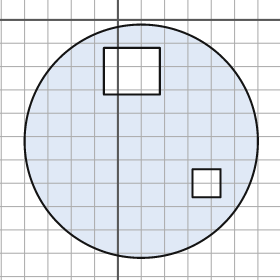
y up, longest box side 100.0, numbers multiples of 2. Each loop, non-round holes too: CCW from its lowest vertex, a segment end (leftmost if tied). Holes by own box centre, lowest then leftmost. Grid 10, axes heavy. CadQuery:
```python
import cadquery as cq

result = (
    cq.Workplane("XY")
    .moveTo(10.0, -52.0)
    .circle(50.0)
    .moveTo(32.0, -76.0)
    .lineTo(44.0, -76.0)
    .lineTo(44.0, -64.0)
    .lineTo(32.0, -64.0)
    .close()
    .moveTo(-6.0, -32.0)
    .lineTo(18.0, -32.0)
    .lineTo(18.0, -12.0)
    .lineTo(-6.0, -12.0)
    .close()
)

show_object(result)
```